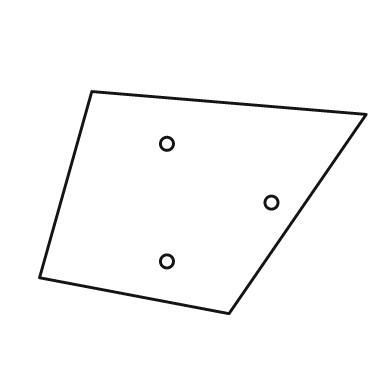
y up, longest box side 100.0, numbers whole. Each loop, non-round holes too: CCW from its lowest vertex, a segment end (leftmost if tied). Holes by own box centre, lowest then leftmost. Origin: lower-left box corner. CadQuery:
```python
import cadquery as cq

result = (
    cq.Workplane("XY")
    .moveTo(58.0, 0.0)
    .lineTo(100.0, 61.0)
    .lineTo(16.0, 68.0)
    .lineTo(0.0, 11.0)
    .close()
    .moveTo(39.0, 16.0)
    .circle(2.0)
    .moveTo(71.0, 34.0)
    .circle(2.0)
    .moveTo(39.0, 52.0)
    .circle(2.0)
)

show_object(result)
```